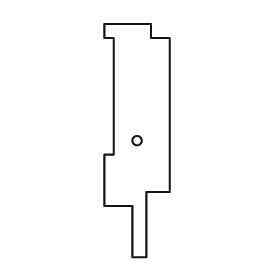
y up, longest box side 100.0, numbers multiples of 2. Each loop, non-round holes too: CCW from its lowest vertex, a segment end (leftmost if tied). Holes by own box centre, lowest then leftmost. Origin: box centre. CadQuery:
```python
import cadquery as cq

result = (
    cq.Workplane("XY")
    .moveTo(-2.0, -50.0)
    .lineTo(4.0, -50.0)
    .lineTo(4.0, -22.0)
    .lineTo(14.0, -22.0)
    .lineTo(14.0, 44.0)
    .lineTo(6.0, 44.0)
    .lineTo(6.0, 50.0)
    .lineTo(-14.0, 50.0)
    .lineTo(-14.0, 44.0)
    .lineTo(-10.0, 44.0)
    .lineTo(-10.0, -6.0)
    .lineTo(-14.0, -6.0)
    .lineTo(-14.0, -28.0)
    .lineTo(-2.0, -28.0)
    .close()
    .moveTo(0.0, 0.0)
    .circle(2.0)
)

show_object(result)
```